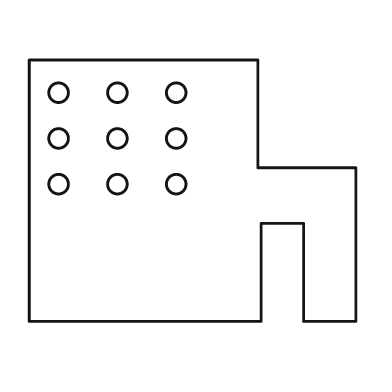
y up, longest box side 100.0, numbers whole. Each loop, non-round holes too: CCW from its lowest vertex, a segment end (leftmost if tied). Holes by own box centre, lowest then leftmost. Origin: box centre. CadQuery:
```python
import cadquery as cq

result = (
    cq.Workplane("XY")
    .moveTo(-50.0, -40.0)
    .lineTo(21.0, -40.0)
    .lineTo(21.0, -10.0)
    .lineTo(34.0, -10.0)
    .lineTo(34.0, -40.0)
    .lineTo(50.0, -40.0)
    .lineTo(50.0, 7.0)
    .lineTo(20.0, 7.0)
    .lineTo(20.0, 40.0)
    .lineTo(-50.0, 40.0)
    .close()
    .moveTo(-41.0, 2.0)
    .circle(3.0)
    .moveTo(-23.0, 2.0)
    .circle(3.0)
    .moveTo(-5.0, 2.0)
    .circle(3.0)
    .moveTo(-41.0, 16.0)
    .circle(3.0)
    .moveTo(-23.0, 16.0)
    .circle(3.0)
    .moveTo(-5.0, 16.0)
    .circle(3.0)
    .moveTo(-41.0, 30.0)
    .circle(3.0)
    .moveTo(-23.0, 30.0)
    .circle(3.0)
    .moveTo(-5.0, 30.0)
    .circle(3.0)
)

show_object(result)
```